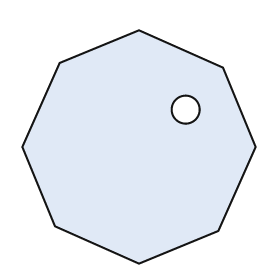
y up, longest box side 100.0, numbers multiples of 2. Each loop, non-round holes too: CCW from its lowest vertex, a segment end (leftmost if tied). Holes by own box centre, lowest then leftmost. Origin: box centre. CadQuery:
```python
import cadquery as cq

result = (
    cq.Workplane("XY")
    .moveTo(0.0, -50.0)
    .lineTo(34.0, -36.0)
    .lineTo(50.0, 0.0)
    .lineTo(36.0, 34.0)
    .lineTo(0.0, 50.0)
    .lineTo(-34.0, 36.0)
    .lineTo(-50.0, 0.0)
    .lineTo(-36.0, -34.0)
    .close()
    .moveTo(20.0, 16.0)
    .circle(6.0)
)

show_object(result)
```